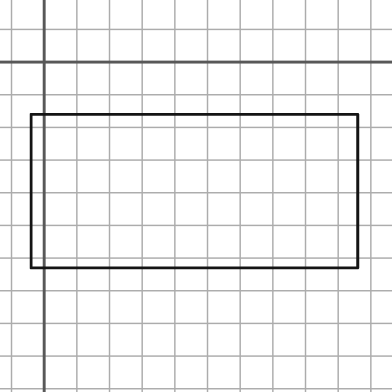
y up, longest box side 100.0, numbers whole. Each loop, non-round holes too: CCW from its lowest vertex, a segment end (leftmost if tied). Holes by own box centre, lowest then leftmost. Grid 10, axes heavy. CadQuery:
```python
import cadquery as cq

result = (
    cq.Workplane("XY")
    .moveTo(-4.0, -63.0)
    .lineTo(96.0, -63.0)
    .lineTo(96.0, -16.0)
    .lineTo(-4.0, -16.0)
    .close()
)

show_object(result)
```